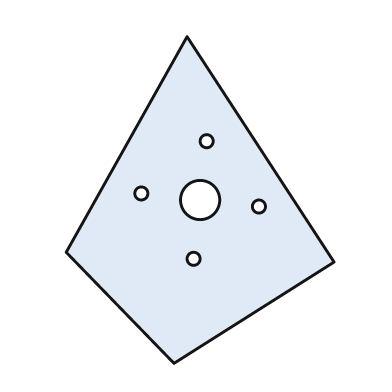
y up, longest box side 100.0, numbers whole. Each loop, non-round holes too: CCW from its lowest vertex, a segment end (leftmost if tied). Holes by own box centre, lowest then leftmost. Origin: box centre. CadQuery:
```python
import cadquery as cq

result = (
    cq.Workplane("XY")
    .moveTo(-8.0, -50.0)
    .lineTo(41.0, -19.0)
    .lineTo(-4.0, 50.0)
    .lineTo(-41.0, -16.0)
    .close()
    .moveTo(-2.0, -18.0)
    .circle(2.0)
    .moveTo(18.0, -2.0)
    .circle(2.0)
    .moveTo(0.0, 0.0)
    .circle(6.0)
    .moveTo(-18.0, 2.0)
    .circle(2.0)
    .moveTo(2.0, 18.0)
    .circle(2.0)
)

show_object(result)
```